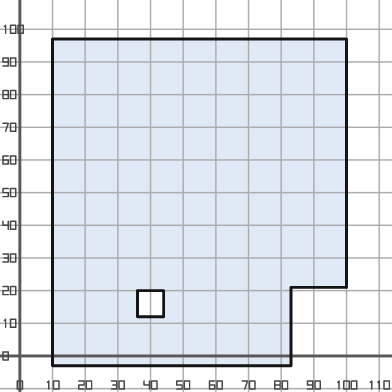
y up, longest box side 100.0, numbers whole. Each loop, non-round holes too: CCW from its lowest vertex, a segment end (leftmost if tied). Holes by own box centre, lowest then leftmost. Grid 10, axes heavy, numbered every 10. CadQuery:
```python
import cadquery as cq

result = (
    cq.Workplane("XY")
    .moveTo(10.0, -3.0)
    .lineTo(83.0, -3.0)
    .lineTo(83.0, 21.0)
    .lineTo(100.0, 21.0)
    .lineTo(100.0, 97.0)
    .lineTo(10.0, 97.0)
    .close()
    .moveTo(36.0, 12.0)
    .lineTo(44.0, 12.0)
    .lineTo(44.0, 20.0)
    .lineTo(36.0, 20.0)
    .close()
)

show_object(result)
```